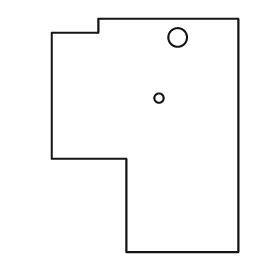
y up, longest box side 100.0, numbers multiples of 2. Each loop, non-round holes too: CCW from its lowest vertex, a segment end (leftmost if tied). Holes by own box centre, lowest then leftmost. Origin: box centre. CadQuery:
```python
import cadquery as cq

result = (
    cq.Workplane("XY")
    .moveTo(-8.0, -50.0)
    .lineTo(40.0, -50.0)
    .lineTo(40.0, 50.0)
    .lineTo(-20.0, 50.0)
    .lineTo(-20.0, 44.0)
    .lineTo(-40.0, 44.0)
    .lineTo(-40.0, -10.0)
    .lineTo(-8.0, -10.0)
    .close()
    .moveTo(6.0, 16.0)
    .circle(2.0)
    .moveTo(14.0, 42.0)
    .circle(4.0)
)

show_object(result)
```